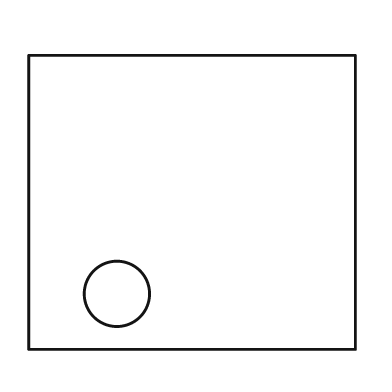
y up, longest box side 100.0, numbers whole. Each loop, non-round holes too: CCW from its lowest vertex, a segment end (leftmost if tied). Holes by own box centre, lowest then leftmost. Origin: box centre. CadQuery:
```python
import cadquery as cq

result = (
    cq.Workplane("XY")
    .moveTo(-50.0, -45.0)
    .lineTo(50.0, -45.0)
    .lineTo(50.0, 45.0)
    .lineTo(-50.0, 45.0)
    .close()
    .moveTo(-23.0, -28.0)
    .circle(10.0)
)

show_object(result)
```